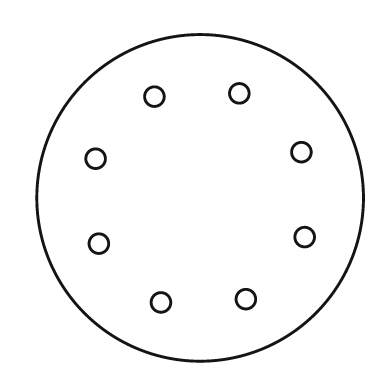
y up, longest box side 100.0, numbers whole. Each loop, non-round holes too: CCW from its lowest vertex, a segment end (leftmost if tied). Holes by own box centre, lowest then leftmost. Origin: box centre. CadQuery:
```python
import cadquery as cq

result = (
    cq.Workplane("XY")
    .moveTo(0.0, 0.0)
    .circle(50.0)
    .moveTo(-12.0, -32.0)
    .circle(3.0)
    .moveTo(14.0, -31.0)
    .circle(3.0)
    .moveTo(-31.0, -14.0)
    .circle(3.0)
    .moveTo(32.0, -12.0)
    .circle(3.0)
    .moveTo(-32.0, 12.0)
    .circle(3.0)
    .moveTo(31.0, 14.0)
    .circle(3.0)
    .moveTo(-14.0, 31.0)
    .circle(3.0)
    .moveTo(12.0, 32.0)
    .circle(3.0)
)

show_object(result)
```